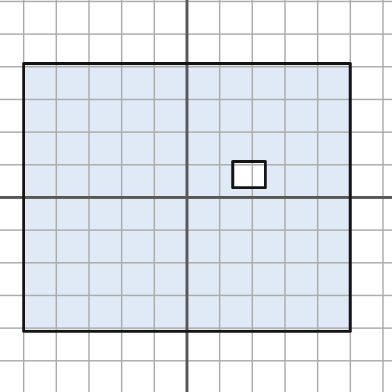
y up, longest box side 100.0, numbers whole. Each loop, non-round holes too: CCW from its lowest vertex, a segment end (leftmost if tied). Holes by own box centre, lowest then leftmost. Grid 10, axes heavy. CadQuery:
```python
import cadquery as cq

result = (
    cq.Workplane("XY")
    .moveTo(-50.0, -41.0)
    .lineTo(50.0, -41.0)
    .lineTo(50.0, 41.0)
    .lineTo(-50.0, 41.0)
    .close()
    .moveTo(14.0, 3.0)
    .lineTo(24.0, 3.0)
    .lineTo(24.0, 11.0)
    .lineTo(14.0, 11.0)
    .close()
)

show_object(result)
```